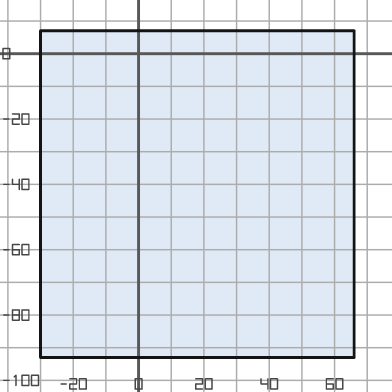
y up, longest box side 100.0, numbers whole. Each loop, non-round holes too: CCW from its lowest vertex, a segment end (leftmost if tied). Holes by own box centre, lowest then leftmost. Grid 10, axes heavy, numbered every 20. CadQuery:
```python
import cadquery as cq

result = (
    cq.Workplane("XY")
    .moveTo(-30.0, -93.0)
    .lineTo(66.0, -93.0)
    .lineTo(66.0, 7.0)
    .lineTo(-30.0, 7.0)
    .close()
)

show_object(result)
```